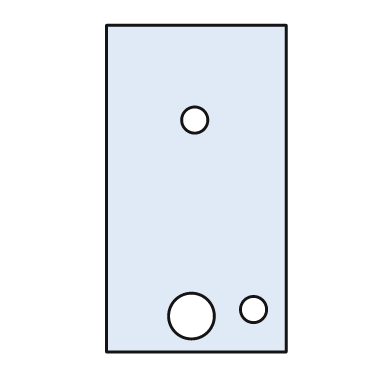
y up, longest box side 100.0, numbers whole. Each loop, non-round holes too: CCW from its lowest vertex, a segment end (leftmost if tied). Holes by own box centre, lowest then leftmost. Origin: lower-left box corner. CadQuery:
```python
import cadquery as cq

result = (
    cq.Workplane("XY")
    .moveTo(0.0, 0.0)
    .lineTo(55.0, 0.0)
    .lineTo(55.0, 100.0)
    .lineTo(0.0, 100.0)
    .close()
    .moveTo(26.0, 11.0)
    .circle(7.0)
    .moveTo(45.0, 13.0)
    .circle(4.0)
    .moveTo(27.0, 71.0)
    .circle(4.0)
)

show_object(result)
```